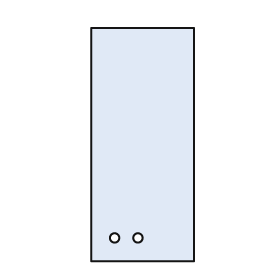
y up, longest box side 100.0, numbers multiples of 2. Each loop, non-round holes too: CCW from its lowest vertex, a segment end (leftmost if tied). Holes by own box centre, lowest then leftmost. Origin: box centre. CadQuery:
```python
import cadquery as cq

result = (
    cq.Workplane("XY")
    .moveTo(-22.0, -50.0)
    .lineTo(22.0, -50.0)
    .lineTo(22.0, 50.0)
    .lineTo(-22.0, 50.0)
    .close()
    .moveTo(-12.0, -40.0)
    .circle(2.0)
    .moveTo(-2.0, -40.0)
    .circle(2.0)
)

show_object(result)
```